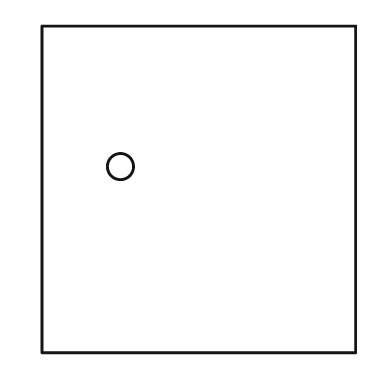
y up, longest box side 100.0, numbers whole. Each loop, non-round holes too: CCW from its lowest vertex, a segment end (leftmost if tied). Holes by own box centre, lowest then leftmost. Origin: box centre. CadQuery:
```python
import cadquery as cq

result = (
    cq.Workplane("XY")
    .moveTo(-48.0, -50.0)
    .lineTo(48.0, -50.0)
    .lineTo(48.0, 50.0)
    .lineTo(-48.0, 50.0)
    .close()
    .moveTo(-24.0, 7.0)
    .circle(4.0)
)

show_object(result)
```